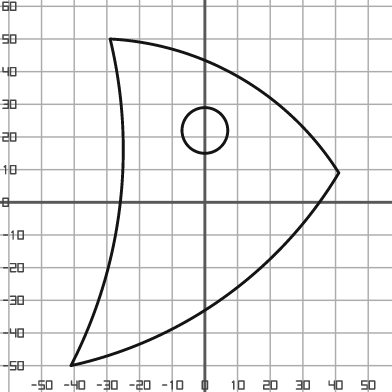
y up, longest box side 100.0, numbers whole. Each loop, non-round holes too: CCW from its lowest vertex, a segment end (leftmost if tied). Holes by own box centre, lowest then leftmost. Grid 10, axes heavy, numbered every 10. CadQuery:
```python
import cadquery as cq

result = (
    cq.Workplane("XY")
    .moveTo(-41.0, -50.0)
    .threePointArc((6.0, -29.0), (41.0, 9.0))
    .threePointArc((11.0, 38.0), (-29.0, 50.0))
    .threePointArc((-26.0, -1.0), (-41.0, -50.0))
    .close()
    .moveTo(0.0, 22.0)
    .circle(7.0)
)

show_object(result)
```